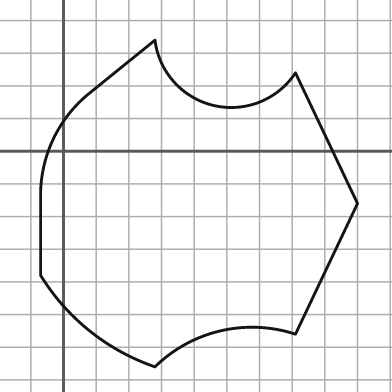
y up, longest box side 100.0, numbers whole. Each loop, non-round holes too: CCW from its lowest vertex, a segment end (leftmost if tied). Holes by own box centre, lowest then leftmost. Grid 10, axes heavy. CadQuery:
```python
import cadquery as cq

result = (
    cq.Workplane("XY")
    .moveTo(28.0, -66.0)
    .threePointArc((48.0, -55.0), (71.0, -56.0))
    .lineTo(90.0, -16.0)
    .lineTo(71.0, 24.0)
    .threePointArc((46.0, 14.0), (28.0, 34.0))
    .lineTo(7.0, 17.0)
    .threePointArc((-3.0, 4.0), (-7.0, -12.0))
    .lineTo(-7.0, -38.0)
    .threePointArc((8.0, -55.0), (28.0, -66.0))
    .close()
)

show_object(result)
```